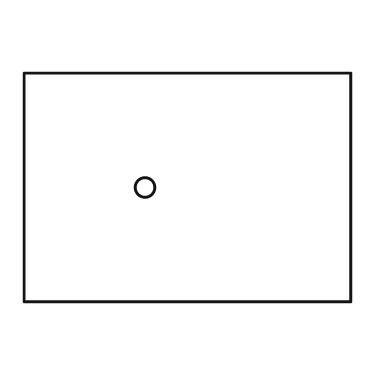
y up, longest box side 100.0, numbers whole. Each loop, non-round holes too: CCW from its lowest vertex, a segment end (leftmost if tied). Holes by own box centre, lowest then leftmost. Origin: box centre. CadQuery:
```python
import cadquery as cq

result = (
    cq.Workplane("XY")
    .moveTo(-50.0, -35.0)
    .lineTo(50.0, -35.0)
    .lineTo(50.0, 35.0)
    .lineTo(-50.0, 35.0)
    .close()
    .moveTo(-13.0, 0.0)
    .circle(3.0)
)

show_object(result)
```